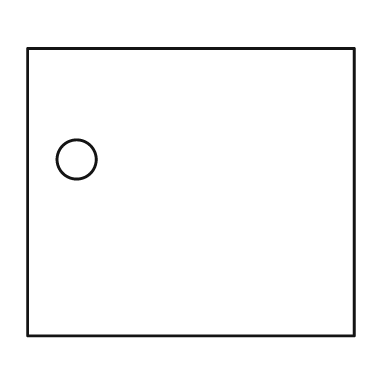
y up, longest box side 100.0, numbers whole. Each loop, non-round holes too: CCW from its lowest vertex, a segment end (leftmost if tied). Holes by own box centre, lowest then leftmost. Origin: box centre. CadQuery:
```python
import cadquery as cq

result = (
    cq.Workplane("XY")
    .moveTo(-50.0, -44.0)
    .lineTo(50.0, -44.0)
    .lineTo(50.0, 44.0)
    .lineTo(-50.0, 44.0)
    .close()
    .moveTo(-35.0, 10.0)
    .circle(6.0)
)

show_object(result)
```